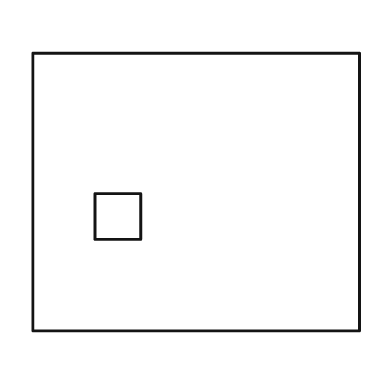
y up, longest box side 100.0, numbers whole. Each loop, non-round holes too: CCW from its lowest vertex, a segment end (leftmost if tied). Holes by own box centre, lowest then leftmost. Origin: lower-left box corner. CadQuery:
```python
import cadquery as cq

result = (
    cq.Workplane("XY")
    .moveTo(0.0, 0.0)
    .lineTo(100.0, 0.0)
    .lineTo(100.0, 85.0)
    .lineTo(0.0, 85.0)
    .close()
    .moveTo(19.0, 28.0)
    .lineTo(33.0, 28.0)
    .lineTo(33.0, 42.0)
    .lineTo(19.0, 42.0)
    .close()
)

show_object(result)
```